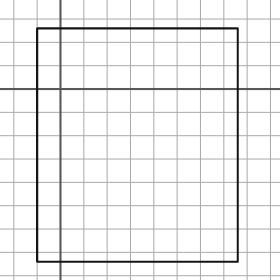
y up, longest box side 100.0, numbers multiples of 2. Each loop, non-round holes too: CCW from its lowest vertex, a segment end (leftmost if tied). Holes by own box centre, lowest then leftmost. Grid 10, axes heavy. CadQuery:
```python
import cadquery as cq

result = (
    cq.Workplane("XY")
    .moveTo(-10.0, -74.0)
    .lineTo(76.0, -74.0)
    .lineTo(76.0, 26.0)
    .lineTo(-10.0, 26.0)
    .close()
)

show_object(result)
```